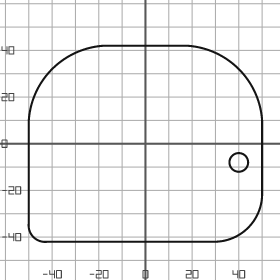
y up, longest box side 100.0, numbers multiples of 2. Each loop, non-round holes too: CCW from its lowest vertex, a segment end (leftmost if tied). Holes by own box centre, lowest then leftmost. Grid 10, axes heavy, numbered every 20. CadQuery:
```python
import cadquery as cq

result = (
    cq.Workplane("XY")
    .moveTo(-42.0, -42.0)
    .lineTo(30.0, -42.0)
    .threePointArc((44.0, -36.0), (50.0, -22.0))
    .lineTo(50.0, 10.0)
    .threePointArc((40.0, 32.0), (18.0, 42.0))
    .lineTo(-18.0, 42.0)
    .threePointArc((-40.0, 32.0), (-50.0, 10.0))
    .lineTo(-50.0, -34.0)
    .threePointArc((-48.0, -40.0), (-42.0, -42.0))
    .close()
    .moveTo(40.0, -8.0)
    .circle(4.0)
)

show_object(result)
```